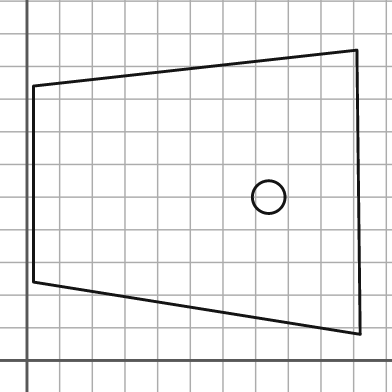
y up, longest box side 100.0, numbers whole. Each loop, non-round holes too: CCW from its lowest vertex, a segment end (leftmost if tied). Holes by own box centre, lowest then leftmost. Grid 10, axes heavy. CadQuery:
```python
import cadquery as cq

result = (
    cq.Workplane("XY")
    .moveTo(102.0, 8.0)
    .lineTo(101.0, 95.0)
    .lineTo(2.0, 84.0)
    .lineTo(2.0, 24.0)
    .close()
    .moveTo(74.0, 50.0)
    .circle(5.0)
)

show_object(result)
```